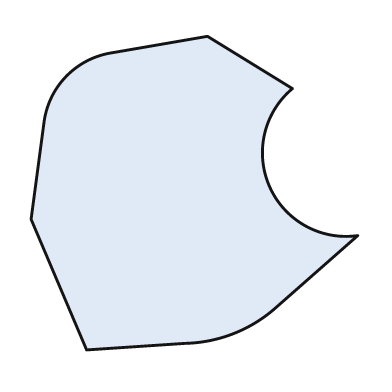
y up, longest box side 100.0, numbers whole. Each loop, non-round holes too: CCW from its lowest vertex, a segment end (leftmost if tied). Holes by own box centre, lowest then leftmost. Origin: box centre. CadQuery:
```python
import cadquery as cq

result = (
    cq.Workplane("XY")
    .moveTo(-33.0, -48.0)
    .lineTo(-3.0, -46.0)
    .threePointArc((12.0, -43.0), (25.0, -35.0))
    .lineTo(50.0, -13.0)
    .threePointArc((23.0, 2.0), (30.0, 32.0))
    .lineTo(4.0, 48.0)
    .lineTo(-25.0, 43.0)
    .threePointArc((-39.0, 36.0), (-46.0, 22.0))
    .lineTo(-50.0, -8.0)
    .close()
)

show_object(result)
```